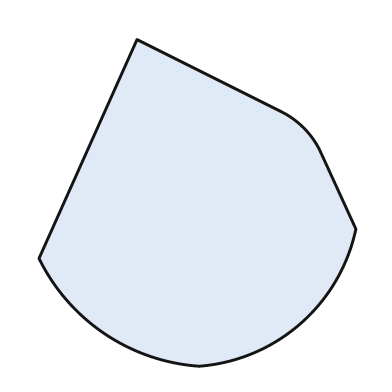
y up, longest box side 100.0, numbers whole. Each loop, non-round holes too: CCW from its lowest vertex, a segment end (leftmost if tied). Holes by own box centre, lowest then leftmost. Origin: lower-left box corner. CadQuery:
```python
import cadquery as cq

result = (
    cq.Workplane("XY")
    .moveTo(49.0, 0.0)
    .threePointArc((80.0, 13.0), (97.0, 42.0))
    .lineTo(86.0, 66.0)
    .threePointArc((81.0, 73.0), (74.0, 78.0))
    .lineTo(30.0, 100.0)
    .lineTo(0.0, 33.0)
    .threePointArc((20.0, 10.0), (49.0, 0.0))
    .close()
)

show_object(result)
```